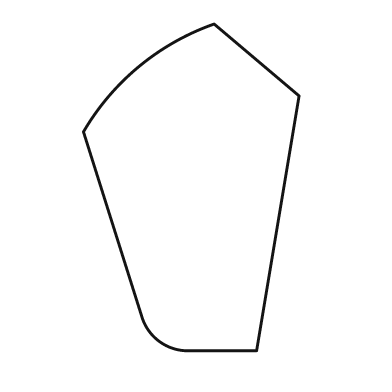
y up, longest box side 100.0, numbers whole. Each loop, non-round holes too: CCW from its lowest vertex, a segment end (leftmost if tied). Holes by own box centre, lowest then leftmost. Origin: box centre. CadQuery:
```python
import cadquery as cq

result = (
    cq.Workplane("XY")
    .moveTo(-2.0, -50.0)
    .lineTo(20.0, -50.0)
    .lineTo(33.0, 28.0)
    .lineTo(7.0, 50.0)
    .threePointArc((-16.0, 37.0), (-33.0, 17.0))
    .lineTo(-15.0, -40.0)
    .threePointArc((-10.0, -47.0), (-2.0, -50.0))
    .close()
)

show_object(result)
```